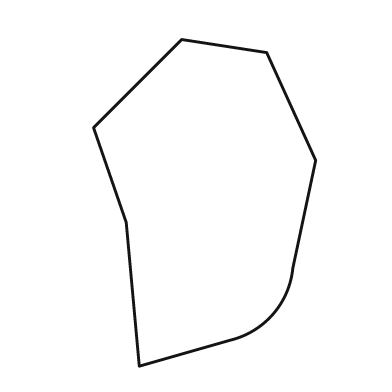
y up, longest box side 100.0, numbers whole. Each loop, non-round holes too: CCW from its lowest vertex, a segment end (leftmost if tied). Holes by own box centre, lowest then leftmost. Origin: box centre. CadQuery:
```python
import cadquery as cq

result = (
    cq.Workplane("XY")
    .moveTo(-20.0, -50.0)
    .lineTo(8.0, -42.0)
    .threePointArc((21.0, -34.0), (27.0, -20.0))
    .lineTo(34.0, 13.0)
    .lineTo(19.0, 46.0)
    .lineTo(-7.0, 50.0)
    .lineTo(-34.0, 23.0)
    .lineTo(-24.0, -6.0)
    .close()
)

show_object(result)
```